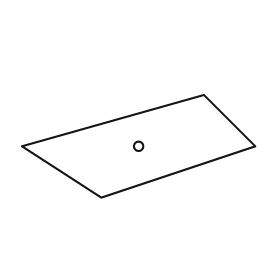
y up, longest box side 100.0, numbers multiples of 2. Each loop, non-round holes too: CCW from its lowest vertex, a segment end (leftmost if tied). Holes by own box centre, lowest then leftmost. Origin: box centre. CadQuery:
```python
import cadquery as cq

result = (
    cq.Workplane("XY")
    .moveTo(-16.0, -22.0)
    .lineTo(50.0, 0.0)
    .lineTo(28.0, 22.0)
    .lineTo(-50.0, 0.0)
    .close()
    .moveTo(0.0, 0.0)
    .circle(2.0)
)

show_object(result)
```